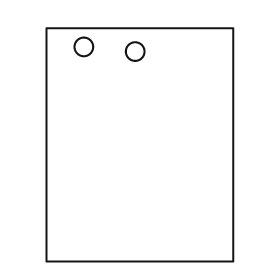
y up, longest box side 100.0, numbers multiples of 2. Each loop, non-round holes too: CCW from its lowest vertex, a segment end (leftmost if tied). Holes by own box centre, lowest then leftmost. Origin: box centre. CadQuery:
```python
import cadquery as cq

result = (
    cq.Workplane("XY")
    .moveTo(-40.0, -50.0)
    .lineTo(40.0, -50.0)
    .lineTo(40.0, 50.0)
    .lineTo(-40.0, 50.0)
    .close()
    .moveTo(-2.0, 40.0)
    .circle(4.0)
    .moveTo(-24.0, 42.0)
    .circle(4.0)
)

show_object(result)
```